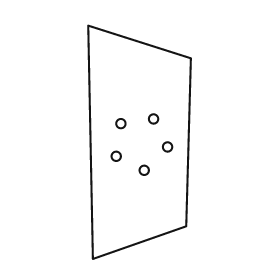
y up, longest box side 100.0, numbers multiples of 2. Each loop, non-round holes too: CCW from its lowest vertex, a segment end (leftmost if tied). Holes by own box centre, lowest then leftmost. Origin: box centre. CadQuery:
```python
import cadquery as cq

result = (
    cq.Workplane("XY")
    .moveTo(-20.0, -50.0)
    .lineTo(20.0, -36.0)
    .lineTo(22.0, 36.0)
    .lineTo(-22.0, 50.0)
    .close()
    .moveTo(2.0, -12.0)
    .circle(2.0)
    .moveTo(-10.0, -6.0)
    .circle(2.0)
    .moveTo(12.0, -2.0)
    .circle(2.0)
    .moveTo(-8.0, 8.0)
    .circle(2.0)
    .moveTo(6.0, 10.0)
    .circle(2.0)
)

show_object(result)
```